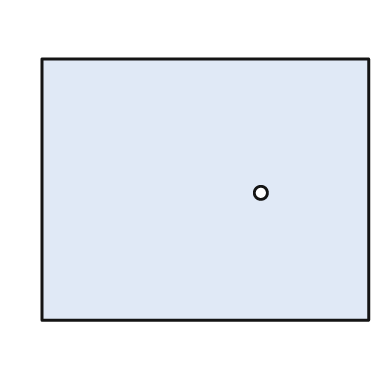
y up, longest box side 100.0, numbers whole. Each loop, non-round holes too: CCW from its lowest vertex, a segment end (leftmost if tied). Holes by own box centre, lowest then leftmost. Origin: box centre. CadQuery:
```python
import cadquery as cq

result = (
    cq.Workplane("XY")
    .moveTo(-50.0, -40.0)
    .lineTo(50.0, -40.0)
    .lineTo(50.0, 40.0)
    .lineTo(-50.0, 40.0)
    .close()
    .moveTo(17.0, -1.0)
    .circle(2.0)
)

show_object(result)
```